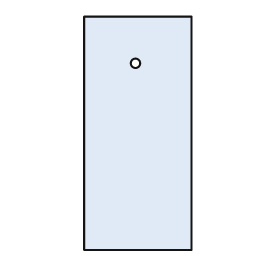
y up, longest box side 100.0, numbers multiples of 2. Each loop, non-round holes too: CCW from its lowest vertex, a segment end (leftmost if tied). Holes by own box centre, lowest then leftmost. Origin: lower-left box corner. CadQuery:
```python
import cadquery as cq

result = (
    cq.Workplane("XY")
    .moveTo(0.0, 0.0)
    .lineTo(46.0, 0.0)
    .lineTo(46.0, 100.0)
    .lineTo(0.0, 100.0)
    .close()
    .moveTo(22.0, 80.0)
    .circle(2.0)
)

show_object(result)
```